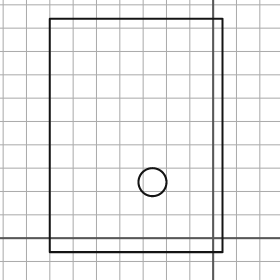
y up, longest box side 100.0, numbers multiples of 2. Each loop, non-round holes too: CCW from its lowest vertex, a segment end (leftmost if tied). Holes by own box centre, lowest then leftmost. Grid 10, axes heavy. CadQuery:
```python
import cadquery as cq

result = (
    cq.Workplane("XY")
    .moveTo(-70.0, -6.0)
    .lineTo(4.0, -6.0)
    .lineTo(4.0, 94.0)
    .lineTo(-70.0, 94.0)
    .close()
    .moveTo(-26.0, 24.0)
    .circle(6.0)
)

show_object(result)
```